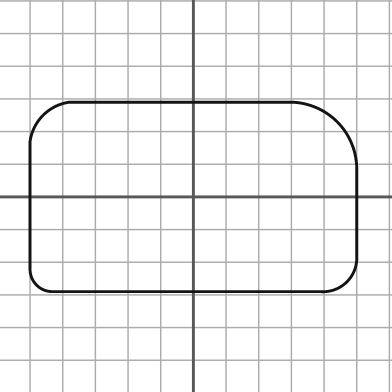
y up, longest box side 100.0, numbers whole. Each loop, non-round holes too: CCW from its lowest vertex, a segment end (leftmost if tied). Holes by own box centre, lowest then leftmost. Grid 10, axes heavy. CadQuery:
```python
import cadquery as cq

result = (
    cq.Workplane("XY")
    .moveTo(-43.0, -29.0)
    .lineTo(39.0, -29.0)
    .threePointArc((47.0, -26.0), (50.0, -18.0))
    .lineTo(50.0, 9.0)
    .threePointArc((44.0, 23.0), (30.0, 29.0))
    .lineTo(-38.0, 29.0)
    .threePointArc((-46.0, 25.0), (-50.0, 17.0))
    .lineTo(-50.0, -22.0)
    .threePointArc((-48.0, -27.0), (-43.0, -29.0))
    .close()
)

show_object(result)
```